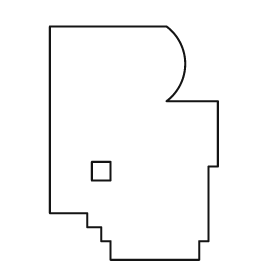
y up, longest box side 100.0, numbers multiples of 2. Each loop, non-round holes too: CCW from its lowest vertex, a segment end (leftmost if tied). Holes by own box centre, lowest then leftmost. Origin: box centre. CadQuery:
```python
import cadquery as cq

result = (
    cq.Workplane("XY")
    .moveTo(-10.0, -50.0)
    .lineTo(28.0, -50.0)
    .lineTo(28.0, -42.0)
    .lineTo(32.0, -42.0)
    .lineTo(32.0, -10.0)
    .lineTo(36.0, -10.0)
    .lineTo(36.0, 18.0)
    .lineTo(14.0, 18.0)
    .threePointArc((22.0, 34.0), (14.0, 50.0))
    .lineTo(-36.0, 50.0)
    .lineTo(-36.0, -30.0)
    .lineTo(-20.0, -30.0)
    .lineTo(-20.0, -36.0)
    .lineTo(-14.0, -36.0)
    .lineTo(-14.0, -42.0)
    .lineTo(-10.0, -42.0)
    .close()
    .moveTo(-18.0, -16.0)
    .lineTo(-10.0, -16.0)
    .lineTo(-10.0, -8.0)
    .lineTo(-18.0, -8.0)
    .close()
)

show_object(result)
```